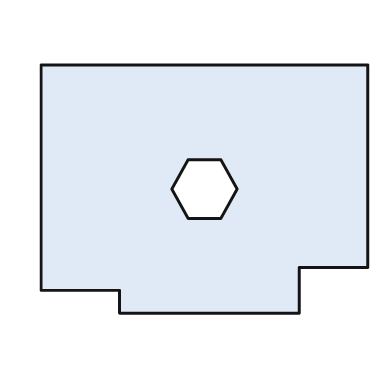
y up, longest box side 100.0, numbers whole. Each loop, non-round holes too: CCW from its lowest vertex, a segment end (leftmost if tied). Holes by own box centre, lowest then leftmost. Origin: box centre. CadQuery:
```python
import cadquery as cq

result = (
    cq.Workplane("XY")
    .moveTo(-26.0, -38.0)
    .lineTo(29.0, -38.0)
    .lineTo(29.0, -24.0)
    .lineTo(50.0, -24.0)
    .lineTo(50.0, 38.0)
    .lineTo(-50.0, 38.0)
    .lineTo(-50.0, -31.0)
    .lineTo(-26.0, -31.0)
    .close()
    .moveTo(-5.0, -9.0)
    .lineTo(5.0, -9.0)
    .lineTo(10.0, 0.0)
    .lineTo(5.0, 9.0)
    .lineTo(-5.0, 9.0)
    .lineTo(-10.0, 0.0)
    .close()
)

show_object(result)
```